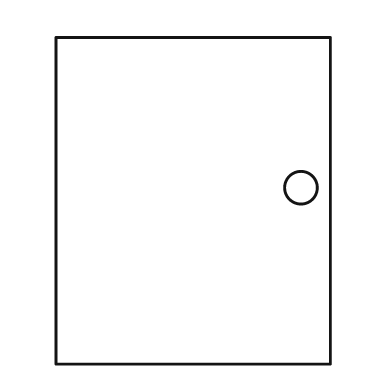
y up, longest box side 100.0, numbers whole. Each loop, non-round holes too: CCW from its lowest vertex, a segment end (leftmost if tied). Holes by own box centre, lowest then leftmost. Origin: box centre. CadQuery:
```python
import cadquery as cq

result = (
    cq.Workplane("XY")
    .moveTo(-42.0, -50.0)
    .lineTo(42.0, -50.0)
    .lineTo(42.0, 50.0)
    .lineTo(-42.0, 50.0)
    .close()
    .moveTo(33.0, 4.0)
    .circle(5.0)
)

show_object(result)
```